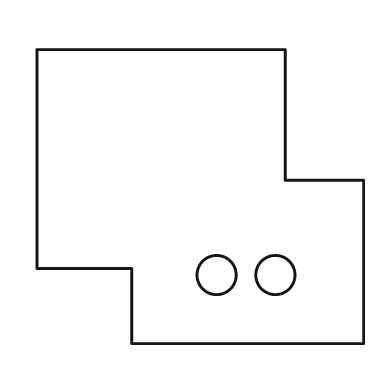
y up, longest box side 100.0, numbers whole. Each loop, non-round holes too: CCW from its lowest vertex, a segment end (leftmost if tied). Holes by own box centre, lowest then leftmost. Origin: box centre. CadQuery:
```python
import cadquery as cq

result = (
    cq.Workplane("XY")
    .moveTo(-21.0, -45.0)
    .lineTo(50.0, -45.0)
    .lineTo(50.0, 5.0)
    .lineTo(26.0, 5.0)
    .lineTo(26.0, 45.0)
    .lineTo(-50.0, 45.0)
    .lineTo(-50.0, -22.0)
    .lineTo(-21.0, -22.0)
    .close()
    .moveTo(5.0, -24.0)
    .circle(6.0)
    .moveTo(23.0, -24.0)
    .circle(6.0)
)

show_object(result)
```